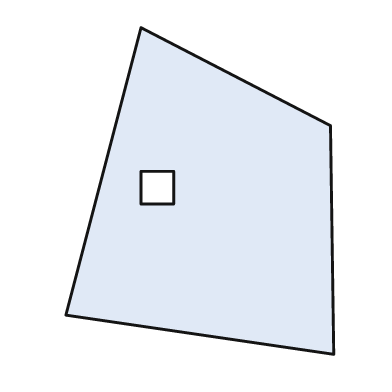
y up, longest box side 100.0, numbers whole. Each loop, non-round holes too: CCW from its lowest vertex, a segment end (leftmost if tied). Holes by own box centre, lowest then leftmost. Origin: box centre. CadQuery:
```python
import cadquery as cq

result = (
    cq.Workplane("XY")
    .moveTo(41.0, -50.0)
    .lineTo(40.0, 20.0)
    .lineTo(-18.0, 50.0)
    .lineTo(-41.0, -38.0)
    .close()
    .moveTo(-18.0, -4.0)
    .lineTo(-8.0, -4.0)
    .lineTo(-8.0, 6.0)
    .lineTo(-18.0, 6.0)
    .close()
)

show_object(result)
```